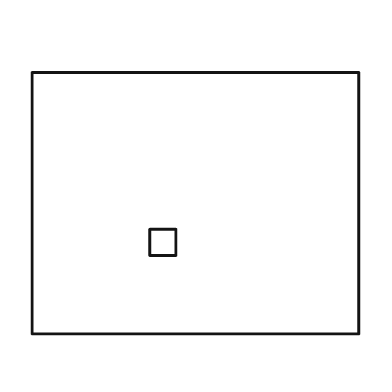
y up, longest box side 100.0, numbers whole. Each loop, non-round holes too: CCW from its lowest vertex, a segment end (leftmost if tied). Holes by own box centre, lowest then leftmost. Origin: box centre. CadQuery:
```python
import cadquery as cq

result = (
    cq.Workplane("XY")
    .moveTo(-50.0, -40.0)
    .lineTo(50.0, -40.0)
    .lineTo(50.0, 40.0)
    .lineTo(-50.0, 40.0)
    .close()
    .moveTo(-14.0, -16.0)
    .lineTo(-6.0, -16.0)
    .lineTo(-6.0, -8.0)
    .lineTo(-14.0, -8.0)
    .close()
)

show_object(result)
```